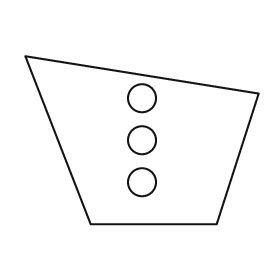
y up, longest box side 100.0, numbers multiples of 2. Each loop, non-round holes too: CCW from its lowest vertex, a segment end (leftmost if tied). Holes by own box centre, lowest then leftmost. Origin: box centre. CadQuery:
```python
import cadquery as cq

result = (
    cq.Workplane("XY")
    .moveTo(-22.0, -36.0)
    .lineTo(32.0, -36.0)
    .lineTo(50.0, 20.0)
    .lineTo(-50.0, 36.0)
    .close()
    .moveTo(0.0, -18.0)
    .circle(6.0)
    .moveTo(0.0, 0.0)
    .circle(6.0)
    .moveTo(0.0, 18.0)
    .circle(6.0)
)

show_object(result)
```